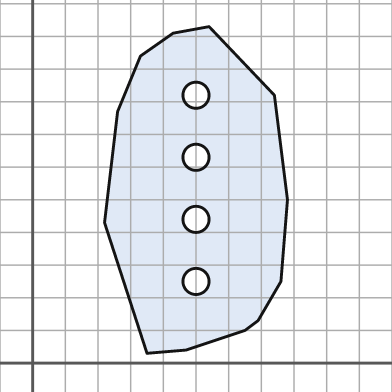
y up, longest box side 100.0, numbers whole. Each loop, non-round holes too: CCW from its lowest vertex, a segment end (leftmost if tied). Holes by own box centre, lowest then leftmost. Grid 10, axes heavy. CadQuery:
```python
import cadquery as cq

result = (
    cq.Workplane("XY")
    .moveTo(35.0, 3.0)
    .lineTo(47.0, 4.0)
    .lineTo(65.0, 10.0)
    .lineTo(69.0, 13.0)
    .lineTo(76.0, 25.0)
    .lineTo(78.0, 50.0)
    .lineTo(74.0, 82.0)
    .lineTo(54.0, 103.0)
    .lineTo(43.0, 101.0)
    .lineTo(33.0, 94.0)
    .lineTo(26.0, 77.0)
    .lineTo(22.0, 43.0)
    .close()
    .moveTo(50.0, 25.0)
    .circle(4.0)
    .moveTo(50.0, 44.0)
    .circle(4.0)
    .moveTo(50.0, 63.0)
    .circle(4.0)
    .moveTo(50.0, 82.0)
    .circle(4.0)
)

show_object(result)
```